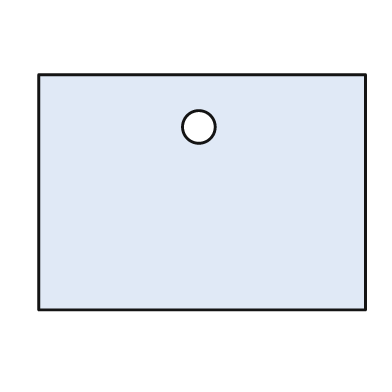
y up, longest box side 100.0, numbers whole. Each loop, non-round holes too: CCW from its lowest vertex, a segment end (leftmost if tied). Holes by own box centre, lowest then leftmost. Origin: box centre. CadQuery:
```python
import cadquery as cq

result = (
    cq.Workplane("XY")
    .moveTo(-50.0, -36.0)
    .lineTo(50.0, -36.0)
    .lineTo(50.0, 36.0)
    .lineTo(-50.0, 36.0)
    .close()
    .moveTo(-1.0, 20.0)
    .circle(5.0)
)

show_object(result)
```